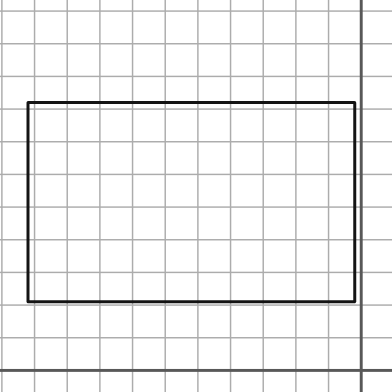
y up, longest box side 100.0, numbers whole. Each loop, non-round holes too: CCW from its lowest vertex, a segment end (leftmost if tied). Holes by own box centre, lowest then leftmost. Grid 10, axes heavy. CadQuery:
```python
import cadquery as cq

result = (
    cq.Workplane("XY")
    .moveTo(-102.0, 21.0)
    .lineTo(-2.0, 21.0)
    .lineTo(-2.0, 82.0)
    .lineTo(-102.0, 82.0)
    .close()
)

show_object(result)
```